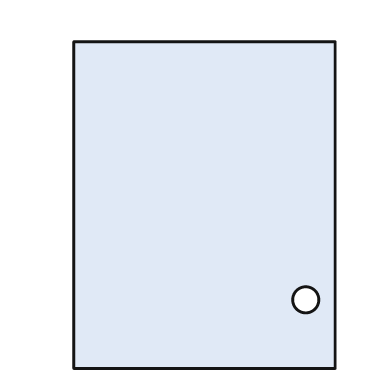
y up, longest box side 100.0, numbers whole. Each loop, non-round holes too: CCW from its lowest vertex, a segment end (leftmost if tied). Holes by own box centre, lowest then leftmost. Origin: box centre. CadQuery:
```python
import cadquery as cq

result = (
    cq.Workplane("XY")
    .moveTo(-40.0, -50.0)
    .lineTo(40.0, -50.0)
    .lineTo(40.0, 50.0)
    .lineTo(-40.0, 50.0)
    .close()
    .moveTo(31.0, -29.0)
    .circle(4.0)
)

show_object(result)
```